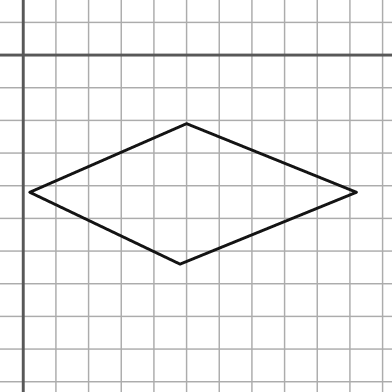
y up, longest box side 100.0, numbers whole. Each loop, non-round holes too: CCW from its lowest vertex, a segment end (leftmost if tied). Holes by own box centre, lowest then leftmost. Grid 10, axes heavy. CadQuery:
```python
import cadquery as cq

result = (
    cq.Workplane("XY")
    .moveTo(48.0, -64.0)
    .lineTo(102.0, -42.0)
    .lineTo(50.0, -21.0)
    .lineTo(2.0, -42.0)
    .close()
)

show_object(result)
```